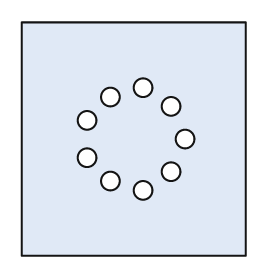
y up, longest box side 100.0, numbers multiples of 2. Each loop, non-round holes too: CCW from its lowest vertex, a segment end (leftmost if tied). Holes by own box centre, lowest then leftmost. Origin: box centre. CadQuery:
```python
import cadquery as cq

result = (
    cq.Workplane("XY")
    .moveTo(-48.0, -50.0)
    .lineTo(48.0, -50.0)
    .lineTo(48.0, 50.0)
    .lineTo(-48.0, 50.0)
    .close()
    .moveTo(4.0, -22.0)
    .circle(4.0)
    .moveTo(-10.0, -18.0)
    .circle(4.0)
    .moveTo(16.0, -14.0)
    .circle(4.0)
    .moveTo(-20.0, -8.0)
    .circle(4.0)
    .moveTo(22.0, 0.0)
    .circle(4.0)
    .moveTo(-20.0, 8.0)
    .circle(4.0)
    .moveTo(16.0, 14.0)
    .circle(4.0)
    .moveTo(-10.0, 18.0)
    .circle(4.0)
    .moveTo(4.0, 22.0)
    .circle(4.0)
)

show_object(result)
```